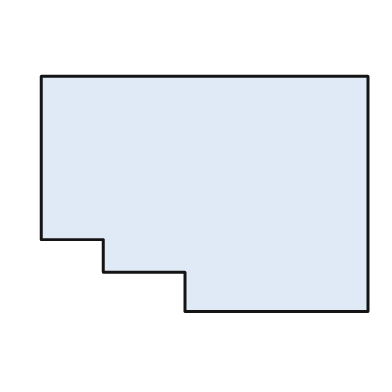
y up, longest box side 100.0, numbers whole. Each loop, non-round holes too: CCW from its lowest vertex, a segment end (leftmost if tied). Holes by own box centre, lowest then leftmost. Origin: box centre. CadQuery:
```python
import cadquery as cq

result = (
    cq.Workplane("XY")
    .moveTo(-6.0, -36.0)
    .lineTo(50.0, -36.0)
    .lineTo(50.0, 36.0)
    .lineTo(-50.0, 36.0)
    .lineTo(-50.0, -14.0)
    .lineTo(-31.0, -14.0)
    .lineTo(-31.0, -24.0)
    .lineTo(-6.0, -24.0)
    .close()
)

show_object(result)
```